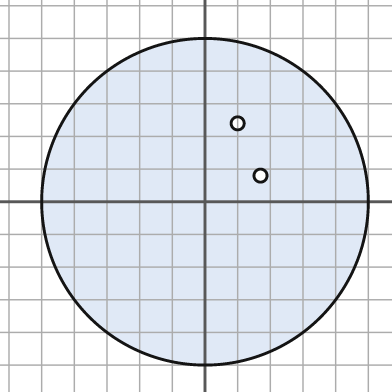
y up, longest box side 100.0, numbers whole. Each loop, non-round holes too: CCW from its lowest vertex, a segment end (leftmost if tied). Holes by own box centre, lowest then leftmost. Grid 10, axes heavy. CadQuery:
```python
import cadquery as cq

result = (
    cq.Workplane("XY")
    .moveTo(0.0, 0.0)
    .circle(50.0)
    .moveTo(17.0, 8.0)
    .circle(2.0)
    .moveTo(10.0, 24.0)
    .circle(2.0)
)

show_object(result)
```